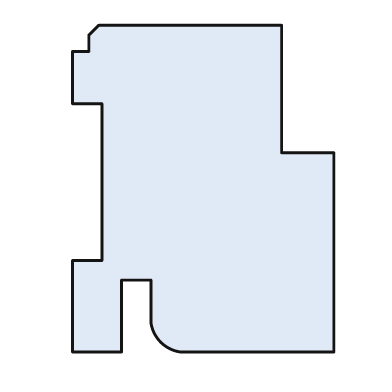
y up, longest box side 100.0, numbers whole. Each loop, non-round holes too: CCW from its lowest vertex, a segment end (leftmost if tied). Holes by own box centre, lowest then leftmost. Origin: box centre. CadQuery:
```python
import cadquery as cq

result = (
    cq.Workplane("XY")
    .moveTo(-40.0, -50.0)
    .lineTo(-25.0, -50.0)
    .lineTo(-25.0, -28.0)
    .lineTo(-16.0, -28.0)
    .lineTo(-16.0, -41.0)
    .threePointArc((-13.0, -47.0), (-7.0, -50.0))
    .lineTo(40.0, -50.0)
    .lineTo(40.0, 11.0)
    .lineTo(24.0, 11.0)
    .lineTo(24.0, 50.0)
    .lineTo(-32.0, 50.0)
    .lineTo(-35.0, 47.0)
    .lineTo(-35.0, 42.0)
    .lineTo(-40.0, 42.0)
    .lineTo(-40.0, 26.0)
    .lineTo(-31.0, 26.0)
    .lineTo(-31.0, -22.0)
    .lineTo(-40.0, -22.0)
    .close()
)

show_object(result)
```